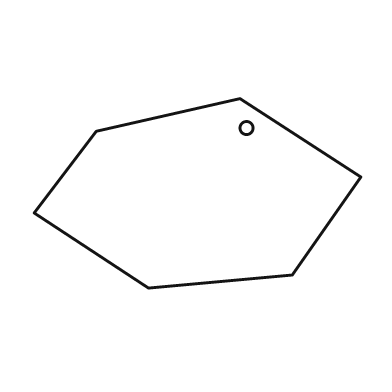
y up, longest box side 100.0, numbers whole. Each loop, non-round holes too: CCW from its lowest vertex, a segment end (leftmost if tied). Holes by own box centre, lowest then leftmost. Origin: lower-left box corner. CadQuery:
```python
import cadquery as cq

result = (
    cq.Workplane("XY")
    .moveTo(35.0, 0.0)
    .lineTo(79.0, 4.0)
    .lineTo(100.0, 34.0)
    .lineTo(63.0, 58.0)
    .lineTo(19.0, 48.0)
    .lineTo(0.0, 23.0)
    .close()
    .moveTo(65.0, 49.0)
    .circle(2.0)
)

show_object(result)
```